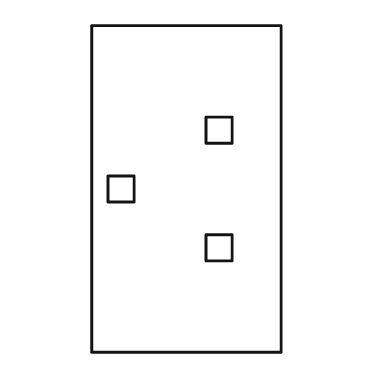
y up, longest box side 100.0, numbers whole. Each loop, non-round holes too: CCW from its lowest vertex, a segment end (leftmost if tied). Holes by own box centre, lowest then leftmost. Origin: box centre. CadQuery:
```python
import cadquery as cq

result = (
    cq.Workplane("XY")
    .moveTo(-29.0, -50.0)
    .lineTo(29.0, -50.0)
    .lineTo(29.0, 50.0)
    .lineTo(-29.0, 50.0)
    .close()
    .moveTo(6.0, -22.0)
    .lineTo(14.0, -22.0)
    .lineTo(14.0, -14.0)
    .lineTo(6.0, -14.0)
    .close()
    .moveTo(-24.0, -4.0)
    .lineTo(-16.0, -4.0)
    .lineTo(-16.0, 4.0)
    .lineTo(-24.0, 4.0)
    .close()
    .moveTo(6.0, 14.0)
    .lineTo(14.0, 14.0)
    .lineTo(14.0, 22.0)
    .lineTo(6.0, 22.0)
    .close()
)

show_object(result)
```